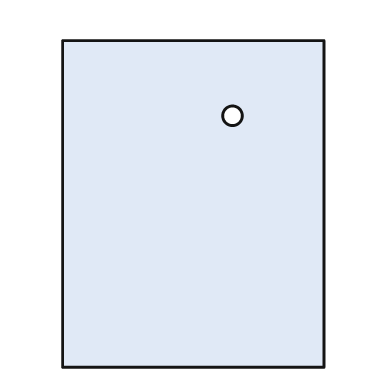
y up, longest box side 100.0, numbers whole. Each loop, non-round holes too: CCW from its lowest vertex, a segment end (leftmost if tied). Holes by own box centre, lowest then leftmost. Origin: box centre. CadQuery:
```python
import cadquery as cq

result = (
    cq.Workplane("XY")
    .moveTo(-40.0, -50.0)
    .lineTo(40.0, -50.0)
    .lineTo(40.0, 50.0)
    .lineTo(-40.0, 50.0)
    .close()
    .moveTo(12.0, 27.0)
    .circle(3.0)
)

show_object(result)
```